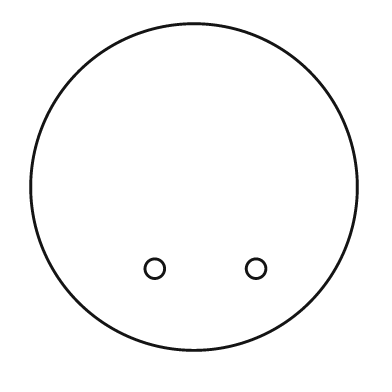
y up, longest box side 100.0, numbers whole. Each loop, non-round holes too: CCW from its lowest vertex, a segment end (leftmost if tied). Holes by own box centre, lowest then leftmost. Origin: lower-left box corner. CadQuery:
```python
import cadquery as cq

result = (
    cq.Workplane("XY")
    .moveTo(50.0, 50.0)
    .circle(50.0)
    .moveTo(38.0, 25.0)
    .circle(3.0)
    .moveTo(69.0, 25.0)
    .circle(3.0)
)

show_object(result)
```